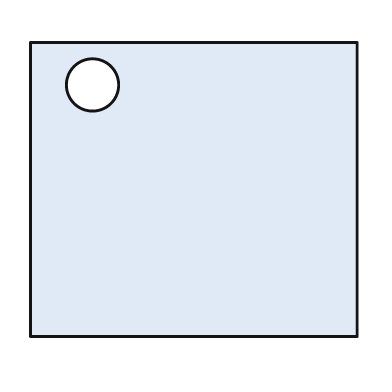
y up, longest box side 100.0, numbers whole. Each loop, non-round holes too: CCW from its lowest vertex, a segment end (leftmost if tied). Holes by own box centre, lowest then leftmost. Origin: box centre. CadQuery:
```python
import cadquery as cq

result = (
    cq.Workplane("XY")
    .moveTo(-50.0, -45.0)
    .lineTo(50.0, -45.0)
    .lineTo(50.0, 45.0)
    .lineTo(-50.0, 45.0)
    .close()
    .moveTo(-31.0, 32.0)
    .circle(8.0)
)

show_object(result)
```